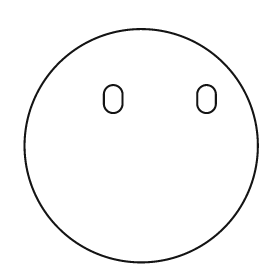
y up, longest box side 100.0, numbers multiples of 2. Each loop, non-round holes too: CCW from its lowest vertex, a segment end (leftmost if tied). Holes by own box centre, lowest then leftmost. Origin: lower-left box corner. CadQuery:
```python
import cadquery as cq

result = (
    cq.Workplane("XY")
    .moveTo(50.0, 50.0)
    .circle(50.0)
    .moveTo(34.0, 68.0)
    .threePointArc((38.0, 64.0), (42.0, 68.0))
    .lineTo(42.0, 72.0)
    .threePointArc((38.0, 76.0), (34.0, 72.0))
    .close()
    .moveTo(74.0, 68.0)
    .threePointArc((78.0, 64.0), (82.0, 68.0))
    .lineTo(82.0, 72.0)
    .threePointArc((78.0, 76.0), (74.0, 72.0))
    .close()
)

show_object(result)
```